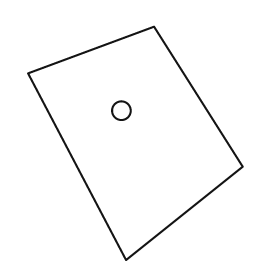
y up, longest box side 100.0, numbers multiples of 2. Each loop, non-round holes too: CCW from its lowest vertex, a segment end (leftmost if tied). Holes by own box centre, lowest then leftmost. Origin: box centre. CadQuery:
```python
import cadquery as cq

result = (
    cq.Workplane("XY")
    .moveTo(-4.0, -50.0)
    .lineTo(46.0, -10.0)
    .lineTo(8.0, 50.0)
    .lineTo(-46.0, 30.0)
    .close()
    .moveTo(-6.0, 14.0)
    .circle(4.0)
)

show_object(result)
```